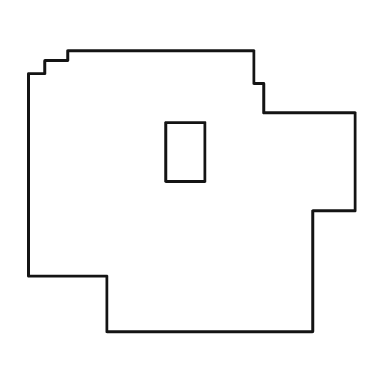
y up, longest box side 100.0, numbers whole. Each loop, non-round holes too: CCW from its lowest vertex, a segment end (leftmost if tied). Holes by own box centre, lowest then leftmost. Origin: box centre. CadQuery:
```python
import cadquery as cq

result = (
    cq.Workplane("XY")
    .moveTo(-26.0, -43.0)
    .lineTo(37.0, -43.0)
    .lineTo(37.0, -6.0)
    .lineTo(50.0, -6.0)
    .lineTo(50.0, 24.0)
    .lineTo(22.0, 24.0)
    .lineTo(22.0, 33.0)
    .lineTo(19.0, 33.0)
    .lineTo(19.0, 43.0)
    .lineTo(-38.0, 43.0)
    .lineTo(-38.0, 40.0)
    .lineTo(-45.0, 40.0)
    .lineTo(-45.0, 36.0)
    .lineTo(-50.0, 36.0)
    .lineTo(-50.0, -26.0)
    .lineTo(-26.0, -26.0)
    .close()
    .moveTo(-8.0, 3.0)
    .lineTo(4.0, 3.0)
    .lineTo(4.0, 21.0)
    .lineTo(-8.0, 21.0)
    .close()
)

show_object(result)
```